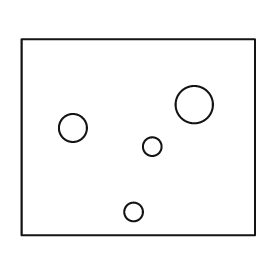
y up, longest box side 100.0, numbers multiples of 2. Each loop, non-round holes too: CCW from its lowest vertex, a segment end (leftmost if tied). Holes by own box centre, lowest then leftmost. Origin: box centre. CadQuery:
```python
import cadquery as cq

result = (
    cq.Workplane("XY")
    .moveTo(-50.0, -42.0)
    .lineTo(50.0, -42.0)
    .lineTo(50.0, 42.0)
    .lineTo(-50.0, 42.0)
    .close()
    .moveTo(-2.0, -32.0)
    .circle(4.0)
    .moveTo(6.0, -4.0)
    .circle(4.0)
    .moveTo(-28.0, 4.0)
    .circle(6.0)
    .moveTo(24.0, 14.0)
    .circle(8.0)
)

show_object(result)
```